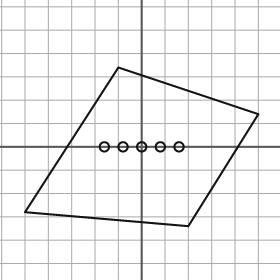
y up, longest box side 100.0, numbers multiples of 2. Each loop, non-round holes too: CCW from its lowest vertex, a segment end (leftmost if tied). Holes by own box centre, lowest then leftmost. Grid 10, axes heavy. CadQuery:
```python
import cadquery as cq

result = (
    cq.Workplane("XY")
    .moveTo(20.0, -34.0)
    .lineTo(50.0, 14.0)
    .lineTo(-10.0, 34.0)
    .lineTo(-50.0, -28.0)
    .close()
    .moveTo(-16.0, 0.0)
    .circle(2.0)
    .moveTo(-8.0, 0.0)
    .circle(2.0)
    .moveTo(0.0, 0.0)
    .circle(2.0)
    .moveTo(8.0, 0.0)
    .circle(2.0)
    .moveTo(16.0, 0.0)
    .circle(2.0)
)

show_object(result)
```